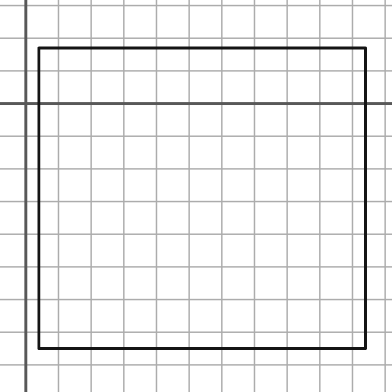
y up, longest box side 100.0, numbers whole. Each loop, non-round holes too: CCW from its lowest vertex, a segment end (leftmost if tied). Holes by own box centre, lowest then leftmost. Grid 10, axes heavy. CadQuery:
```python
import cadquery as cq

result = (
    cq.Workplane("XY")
    .moveTo(4.0, -75.0)
    .lineTo(104.0, -75.0)
    .lineTo(104.0, 17.0)
    .lineTo(4.0, 17.0)
    .close()
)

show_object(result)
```